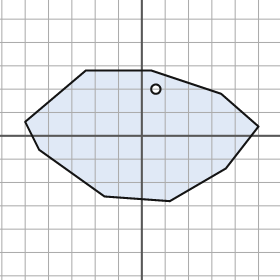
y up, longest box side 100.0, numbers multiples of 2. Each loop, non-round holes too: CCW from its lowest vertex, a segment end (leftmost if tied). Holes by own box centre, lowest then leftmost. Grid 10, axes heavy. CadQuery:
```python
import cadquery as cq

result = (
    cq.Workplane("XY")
    .moveTo(12.0, -28.0)
    .lineTo(36.0, -14.0)
    .lineTo(50.0, 4.0)
    .lineTo(34.0, 18.0)
    .lineTo(4.0, 28.0)
    .lineTo(-24.0, 28.0)
    .lineTo(-50.0, 6.0)
    .lineTo(-44.0, -6.0)
    .lineTo(-16.0, -26.0)
    .close()
    .moveTo(6.0, 20.0)
    .circle(2.0)
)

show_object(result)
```